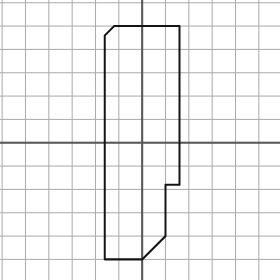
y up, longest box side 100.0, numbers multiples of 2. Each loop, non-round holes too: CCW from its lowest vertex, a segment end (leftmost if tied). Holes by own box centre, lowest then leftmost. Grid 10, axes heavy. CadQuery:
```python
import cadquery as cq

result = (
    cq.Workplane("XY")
    .moveTo(-16.0, -50.0)
    .lineTo(0.0, -50.0)
    .lineTo(10.0, -40.0)
    .lineTo(10.0, -18.0)
    .lineTo(16.0, -18.0)
    .lineTo(16.0, 50.0)
    .lineTo(-12.0, 50.0)
    .lineTo(-16.0, 46.0)
    .close()
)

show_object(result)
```